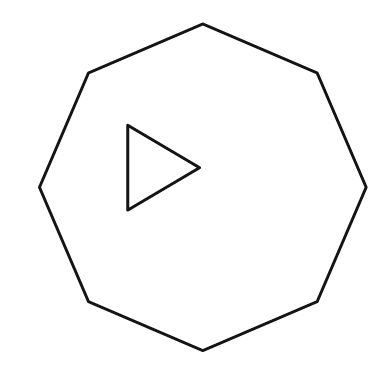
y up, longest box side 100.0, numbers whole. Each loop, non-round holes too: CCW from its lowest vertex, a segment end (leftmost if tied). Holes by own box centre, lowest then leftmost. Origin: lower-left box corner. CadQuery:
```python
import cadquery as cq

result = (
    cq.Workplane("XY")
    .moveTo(50.0, 0.0)
    .lineTo(85.0, 15.0)
    .lineTo(100.0, 50.0)
    .lineTo(85.0, 85.0)
    .lineTo(50.0, 100.0)
    .lineTo(15.0, 85.0)
    .lineTo(0.0, 50.0)
    .lineTo(15.0, 15.0)
    .close()
    .moveTo(27.0, 43.0)
    .lineTo(49.0, 56.0)
    .lineTo(27.0, 69.0)
    .close()
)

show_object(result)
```